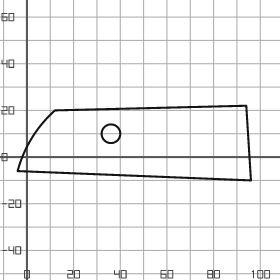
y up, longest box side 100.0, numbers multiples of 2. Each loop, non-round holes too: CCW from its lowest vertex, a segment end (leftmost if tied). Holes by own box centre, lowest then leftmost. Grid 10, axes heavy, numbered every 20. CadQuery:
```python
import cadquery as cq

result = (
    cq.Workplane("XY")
    .moveTo(96.0, -10.0)
    .lineTo(94.0, 22.0)
    .lineTo(12.0, 20.0)
    .threePointArc((2.0, 8.0), (-4.0, -6.0))
    .close()
    .moveTo(36.0, 10.0)
    .circle(4.0)
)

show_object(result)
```